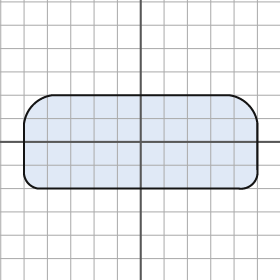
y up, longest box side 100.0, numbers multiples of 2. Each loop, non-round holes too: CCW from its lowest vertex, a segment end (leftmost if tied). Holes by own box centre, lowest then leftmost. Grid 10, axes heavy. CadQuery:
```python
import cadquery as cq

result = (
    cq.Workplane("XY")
    .moveTo(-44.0, -20.0)
    .lineTo(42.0, -20.0)
    .threePointArc((48.0, -18.0), (50.0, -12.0))
    .lineTo(50.0, 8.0)
    .threePointArc((46.0, 16.0), (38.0, 20.0))
    .lineTo(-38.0, 20.0)
    .threePointArc((-46.0, 16.0), (-50.0, 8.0))
    .lineTo(-50.0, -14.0)
    .threePointArc((-48.0, -18.0), (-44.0, -20.0))
    .close()
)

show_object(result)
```